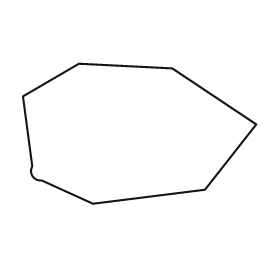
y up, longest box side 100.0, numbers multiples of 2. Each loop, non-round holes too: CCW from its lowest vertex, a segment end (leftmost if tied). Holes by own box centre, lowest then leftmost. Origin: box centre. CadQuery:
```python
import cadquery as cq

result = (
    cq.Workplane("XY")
    .moveTo(-20.0, -30.0)
    .lineTo(28.0, -24.0)
    .lineTo(50.0, 4.0)
    .lineTo(14.0, 28.0)
    .lineTo(-26.0, 30.0)
    .lineTo(-50.0, 16.0)
    .lineTo(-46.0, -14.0)
    .threePointArc((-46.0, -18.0), (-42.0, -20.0))
    .close()
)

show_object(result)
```